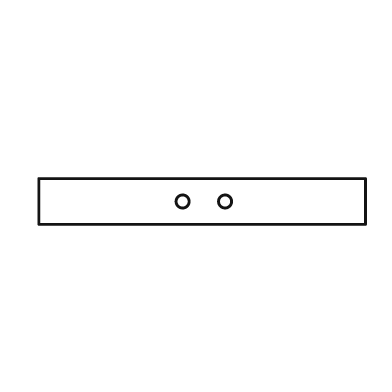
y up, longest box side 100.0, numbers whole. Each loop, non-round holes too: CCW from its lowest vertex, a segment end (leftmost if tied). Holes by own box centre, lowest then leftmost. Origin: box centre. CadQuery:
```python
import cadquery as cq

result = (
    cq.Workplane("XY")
    .moveTo(-50.0, -7.0)
    .lineTo(50.0, -7.0)
    .lineTo(50.0, 7.0)
    .lineTo(-50.0, 7.0)
    .close()
    .moveTo(-6.0, 0.0)
    .circle(2.0)
    .moveTo(7.0, 0.0)
    .circle(2.0)
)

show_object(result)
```